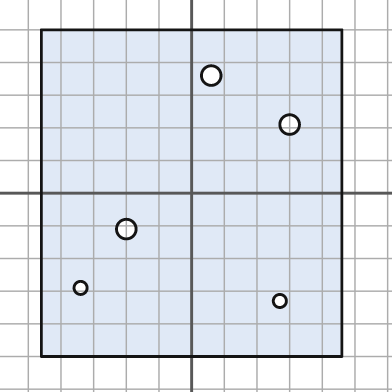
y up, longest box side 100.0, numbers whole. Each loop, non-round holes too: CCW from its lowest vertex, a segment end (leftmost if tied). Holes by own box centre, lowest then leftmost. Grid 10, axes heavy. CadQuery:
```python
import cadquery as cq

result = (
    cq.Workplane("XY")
    .moveTo(-46.0, -50.0)
    .lineTo(46.0, -50.0)
    .lineTo(46.0, 50.0)
    .lineTo(-46.0, 50.0)
    .close()
    .moveTo(27.0, -33.0)
    .circle(2.0)
    .moveTo(-34.0, -29.0)
    .circle(2.0)
    .moveTo(-20.0, -11.0)
    .circle(3.0)
    .moveTo(30.0, 21.0)
    .circle(3.0)
    .moveTo(6.0, 36.0)
    .circle(3.0)
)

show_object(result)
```